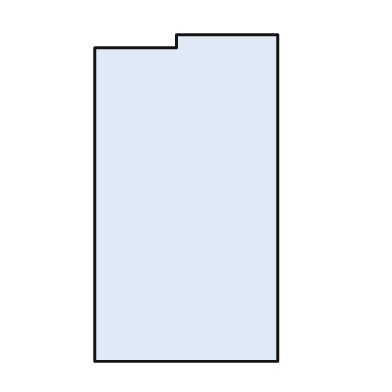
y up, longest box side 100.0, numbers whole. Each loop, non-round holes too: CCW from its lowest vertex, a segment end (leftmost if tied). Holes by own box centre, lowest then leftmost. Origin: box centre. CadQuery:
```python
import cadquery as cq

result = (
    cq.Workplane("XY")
    .moveTo(-28.0, -50.0)
    .lineTo(28.0, -50.0)
    .lineTo(28.0, 50.0)
    .lineTo(-3.0, 50.0)
    .lineTo(-3.0, 46.0)
    .lineTo(-28.0, 46.0)
    .close()
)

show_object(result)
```